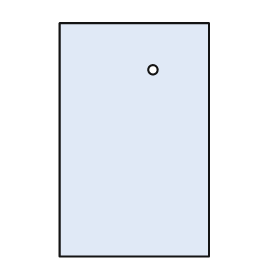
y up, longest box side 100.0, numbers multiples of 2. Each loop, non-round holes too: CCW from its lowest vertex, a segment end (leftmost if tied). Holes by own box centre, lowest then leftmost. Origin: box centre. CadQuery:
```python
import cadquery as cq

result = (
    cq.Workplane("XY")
    .moveTo(-32.0, -50.0)
    .lineTo(32.0, -50.0)
    .lineTo(32.0, 50.0)
    .lineTo(-32.0, 50.0)
    .close()
    .moveTo(8.0, 30.0)
    .circle(2.0)
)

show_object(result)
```